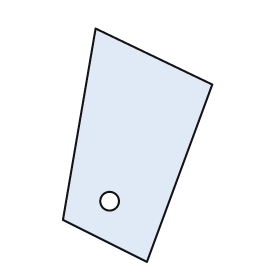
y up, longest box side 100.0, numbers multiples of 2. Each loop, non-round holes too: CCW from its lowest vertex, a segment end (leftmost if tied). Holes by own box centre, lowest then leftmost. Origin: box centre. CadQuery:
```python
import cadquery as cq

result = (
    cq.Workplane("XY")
    .moveTo(4.0, -50.0)
    .lineTo(32.0, 26.0)
    .lineTo(-18.0, 50.0)
    .lineTo(-32.0, -32.0)
    .close()
    .moveTo(-12.0, -24.0)
    .circle(4.0)
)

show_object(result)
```